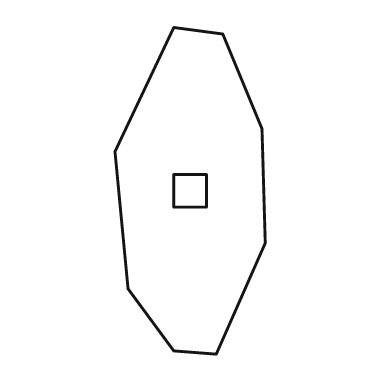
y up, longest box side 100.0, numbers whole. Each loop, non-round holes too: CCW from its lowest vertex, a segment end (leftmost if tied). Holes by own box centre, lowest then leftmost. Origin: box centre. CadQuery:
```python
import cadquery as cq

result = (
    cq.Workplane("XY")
    .moveTo(8.0, -50.0)
    .lineTo(23.0, -16.0)
    .lineTo(22.0, 19.0)
    .lineTo(10.0, 48.0)
    .lineTo(-5.0, 50.0)
    .lineTo(-23.0, 12.0)
    .lineTo(-19.0, -30.0)
    .lineTo(-5.0, -49.0)
    .close()
    .moveTo(-5.0, -5.0)
    .lineTo(5.0, -5.0)
    .lineTo(5.0, 5.0)
    .lineTo(-5.0, 5.0)
    .close()
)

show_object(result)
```